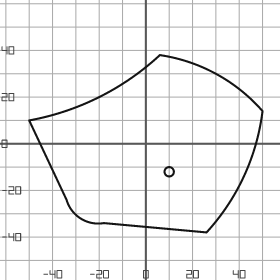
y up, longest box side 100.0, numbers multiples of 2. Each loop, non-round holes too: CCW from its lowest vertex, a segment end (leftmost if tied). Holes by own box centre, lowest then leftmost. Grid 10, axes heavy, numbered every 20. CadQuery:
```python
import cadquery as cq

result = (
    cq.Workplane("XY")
    .moveTo(26.0, -38.0)
    .threePointArc((42.0, -14.0), (50.0, 14.0))
    .threePointArc((30.0, 30.0), (6.0, 38.0))
    .threePointArc((-20.0, 20.0), (-50.0, 10.0))
    .lineTo(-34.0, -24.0)
    .threePointArc((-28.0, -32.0), (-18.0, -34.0))
    .close()
    .moveTo(10.0, -12.0)
    .circle(2.0)
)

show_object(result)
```